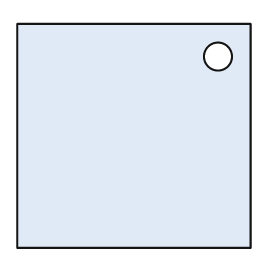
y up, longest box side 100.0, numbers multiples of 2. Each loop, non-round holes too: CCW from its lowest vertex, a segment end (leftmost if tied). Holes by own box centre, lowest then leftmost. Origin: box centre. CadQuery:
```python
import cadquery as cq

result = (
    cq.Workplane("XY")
    .moveTo(-50.0, -48.0)
    .lineTo(50.0, -48.0)
    .lineTo(50.0, 48.0)
    .lineTo(-50.0, 48.0)
    .close()
    .moveTo(36.0, 34.0)
    .circle(6.0)
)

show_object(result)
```